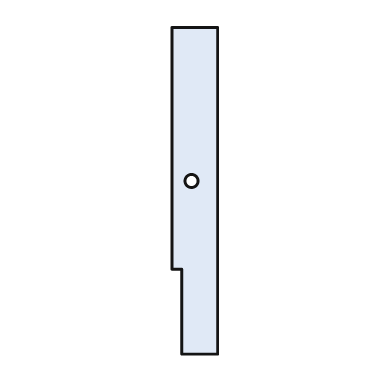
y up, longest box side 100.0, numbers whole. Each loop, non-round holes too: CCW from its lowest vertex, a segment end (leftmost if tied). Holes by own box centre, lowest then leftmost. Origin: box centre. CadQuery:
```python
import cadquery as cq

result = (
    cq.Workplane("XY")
    .moveTo(-4.0, -50.0)
    .lineTo(7.0, -50.0)
    .lineTo(7.0, 50.0)
    .lineTo(-7.0, 50.0)
    .lineTo(-7.0, -24.0)
    .lineTo(-4.0, -24.0)
    .close()
    .moveTo(-1.0, 3.0)
    .circle(2.0)
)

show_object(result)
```